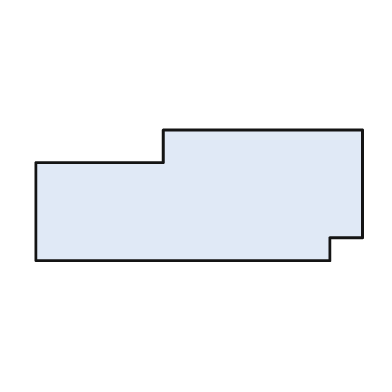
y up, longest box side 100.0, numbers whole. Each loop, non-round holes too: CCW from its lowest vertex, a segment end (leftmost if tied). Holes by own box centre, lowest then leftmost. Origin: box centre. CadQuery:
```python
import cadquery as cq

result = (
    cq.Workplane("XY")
    .moveTo(-50.0, -20.0)
    .lineTo(40.0, -20.0)
    .lineTo(40.0, -13.0)
    .lineTo(50.0, -13.0)
    .lineTo(50.0, 20.0)
    .lineTo(-11.0, 20.0)
    .lineTo(-11.0, 10.0)
    .lineTo(-50.0, 10.0)
    .close()
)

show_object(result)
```